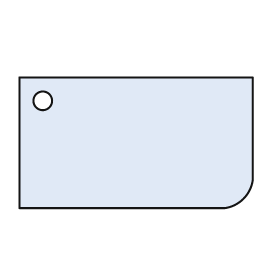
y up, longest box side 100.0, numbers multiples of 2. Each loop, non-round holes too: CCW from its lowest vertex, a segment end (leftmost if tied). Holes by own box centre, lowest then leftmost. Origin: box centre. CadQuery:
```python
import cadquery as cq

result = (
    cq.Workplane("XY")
    .moveTo(-50.0, -28.0)
    .lineTo(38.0, -28.0)
    .threePointArc((46.0, -24.0), (50.0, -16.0))
    .lineTo(50.0, 28.0)
    .lineTo(-50.0, 28.0)
    .close()
    .moveTo(-40.0, 18.0)
    .circle(4.0)
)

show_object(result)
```